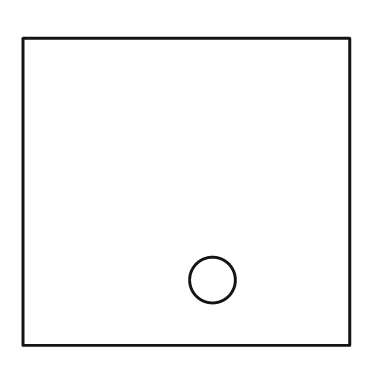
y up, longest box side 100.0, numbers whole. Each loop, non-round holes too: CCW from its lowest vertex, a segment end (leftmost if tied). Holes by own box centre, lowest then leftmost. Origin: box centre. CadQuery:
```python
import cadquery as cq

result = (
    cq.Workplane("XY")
    .moveTo(-50.0, -47.0)
    .lineTo(50.0, -47.0)
    .lineTo(50.0, 47.0)
    .lineTo(-50.0, 47.0)
    .close()
    .moveTo(8.0, -27.0)
    .circle(7.0)
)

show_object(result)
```